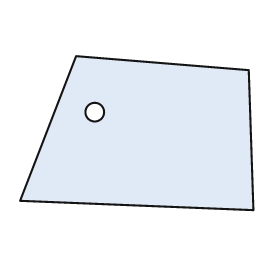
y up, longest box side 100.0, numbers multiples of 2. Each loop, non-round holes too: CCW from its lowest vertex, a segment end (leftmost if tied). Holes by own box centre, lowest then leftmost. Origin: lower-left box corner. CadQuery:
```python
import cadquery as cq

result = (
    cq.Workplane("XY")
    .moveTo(100.0, 0.0)
    .lineTo(98.0, 60.0)
    .lineTo(24.0, 66.0)
    .lineTo(0.0, 4.0)
    .close()
    .moveTo(32.0, 42.0)
    .circle(4.0)
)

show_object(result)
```